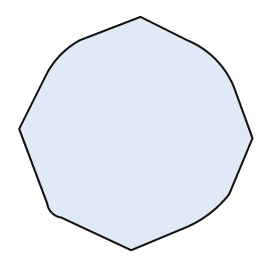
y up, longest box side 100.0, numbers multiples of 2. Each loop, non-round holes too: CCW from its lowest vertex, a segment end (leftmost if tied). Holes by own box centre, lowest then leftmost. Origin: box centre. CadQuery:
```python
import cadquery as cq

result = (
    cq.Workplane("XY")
    .moveTo(-2.0, -50.0)
    .lineTo(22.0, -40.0)
    .threePointArc((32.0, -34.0), (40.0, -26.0))
    .lineTo(50.0, -2.0)
    .lineTo(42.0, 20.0)
    .threePointArc((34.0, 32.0), (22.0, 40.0))
    .lineTo(2.0, 50.0)
    .lineTo(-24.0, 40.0)
    .threePointArc((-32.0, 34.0), (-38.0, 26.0))
    .lineTo(-50.0, 2.0)
    .lineTo(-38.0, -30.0)
    .threePointArc((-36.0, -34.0), (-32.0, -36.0))
    .close()
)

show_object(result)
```